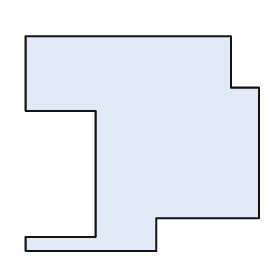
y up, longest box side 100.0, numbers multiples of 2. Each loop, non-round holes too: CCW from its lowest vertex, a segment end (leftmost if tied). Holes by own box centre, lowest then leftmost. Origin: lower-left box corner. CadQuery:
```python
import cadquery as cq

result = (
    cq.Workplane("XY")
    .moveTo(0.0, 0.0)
    .lineTo(56.0, 0.0)
    .lineTo(56.0, 14.0)
    .lineTo(100.0, 14.0)
    .lineTo(100.0, 70.0)
    .lineTo(88.0, 70.0)
    .lineTo(88.0, 92.0)
    .lineTo(0.0, 92.0)
    .lineTo(0.0, 60.0)
    .lineTo(30.0, 60.0)
    .lineTo(30.0, 6.0)
    .lineTo(0.0, 6.0)
    .close()
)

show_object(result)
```